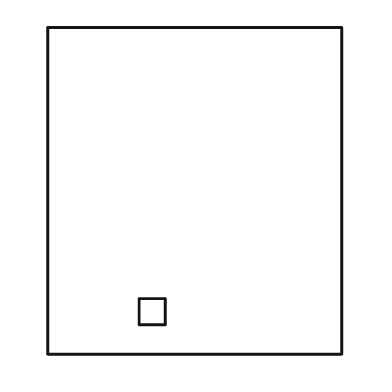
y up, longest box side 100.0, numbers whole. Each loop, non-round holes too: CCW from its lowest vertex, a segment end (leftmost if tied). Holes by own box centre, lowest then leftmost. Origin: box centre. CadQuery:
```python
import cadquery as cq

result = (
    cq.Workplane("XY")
    .moveTo(-45.0, -50.0)
    .lineTo(45.0, -50.0)
    .lineTo(45.0, 50.0)
    .lineTo(-45.0, 50.0)
    .close()
    .moveTo(-17.0, -41.0)
    .lineTo(-9.0, -41.0)
    .lineTo(-9.0, -33.0)
    .lineTo(-17.0, -33.0)
    .close()
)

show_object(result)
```